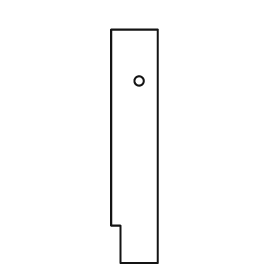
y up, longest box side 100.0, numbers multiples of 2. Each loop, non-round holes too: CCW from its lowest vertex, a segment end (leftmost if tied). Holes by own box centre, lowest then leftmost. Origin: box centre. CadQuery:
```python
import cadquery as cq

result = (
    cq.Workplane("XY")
    .moveTo(-6.0, -50.0)
    .lineTo(10.0, -50.0)
    .lineTo(10.0, 50.0)
    .lineTo(-10.0, 50.0)
    .lineTo(-10.0, -34.0)
    .lineTo(-6.0, -34.0)
    .close()
    .moveTo(2.0, 28.0)
    .circle(2.0)
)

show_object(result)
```